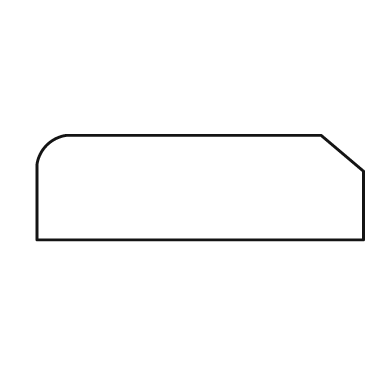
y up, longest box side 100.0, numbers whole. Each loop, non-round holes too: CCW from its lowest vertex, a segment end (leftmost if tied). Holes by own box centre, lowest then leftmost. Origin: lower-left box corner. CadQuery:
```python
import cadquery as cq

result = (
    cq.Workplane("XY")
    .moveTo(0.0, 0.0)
    .lineTo(100.0, 0.0)
    .lineTo(100.0, 21.0)
    .lineTo(87.0, 32.0)
    .lineTo(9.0, 32.0)
    .threePointArc((3.0, 29.0), (0.0, 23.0))
    .close()
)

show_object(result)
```